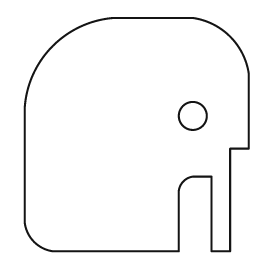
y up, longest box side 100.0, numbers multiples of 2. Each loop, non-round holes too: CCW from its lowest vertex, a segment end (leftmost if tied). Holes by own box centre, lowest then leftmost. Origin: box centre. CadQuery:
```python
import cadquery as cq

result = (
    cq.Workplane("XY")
    .moveTo(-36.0, -50.0)
    .lineTo(18.0, -50.0)
    .lineTo(18.0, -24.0)
    .threePointArc((20.0, -20.0), (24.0, -18.0))
    .lineTo(32.0, -18.0)
    .lineTo(32.0, -50.0)
    .lineTo(40.0, -50.0)
    .lineTo(40.0, -6.0)
    .lineTo(48.0, -6.0)
    .lineTo(48.0, 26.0)
    .threePointArc((40.0, 42.0), (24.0, 50.0))
    .lineTo(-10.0, 50.0)
    .threePointArc((-36.0, 38.0), (-48.0, 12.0))
    .lineTo(-48.0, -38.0)
    .threePointArc((-44.0, -46.0), (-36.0, -50.0))
    .close()
    .moveTo(24.0, 8.0)
    .circle(6.0)
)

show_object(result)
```